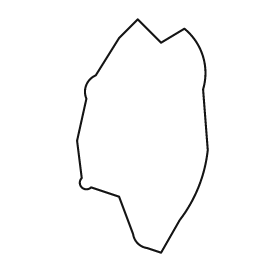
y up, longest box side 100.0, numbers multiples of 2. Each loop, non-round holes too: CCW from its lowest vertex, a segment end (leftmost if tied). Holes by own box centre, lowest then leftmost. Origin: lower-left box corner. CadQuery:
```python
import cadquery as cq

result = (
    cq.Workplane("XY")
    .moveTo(36.0, 0.0)
    .lineTo(44.0, 14.0)
    .threePointArc((52.0, 28.0), (56.0, 44.0))
    .lineTo(54.0, 70.0)
    .threePointArc((54.0, 84.0), (46.0, 96.0))
    .lineTo(36.0, 90.0)
    .lineTo(26.0, 100.0)
    .lineTo(18.0, 92.0)
    .lineTo(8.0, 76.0)
    .threePointArc((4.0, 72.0), (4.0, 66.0))
    .lineTo(0.0, 48.0)
    .lineTo(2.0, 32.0)
    .threePointArc((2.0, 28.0), (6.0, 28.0))
    .lineTo(18.0, 24.0)
    .lineTo(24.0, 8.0)
    .threePointArc((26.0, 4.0), (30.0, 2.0))
    .close()
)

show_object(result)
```